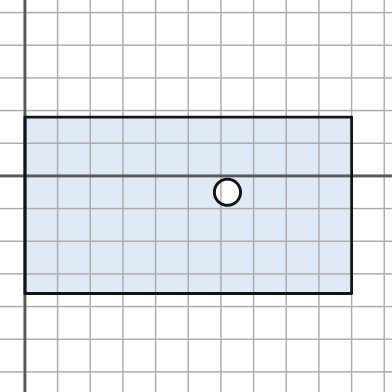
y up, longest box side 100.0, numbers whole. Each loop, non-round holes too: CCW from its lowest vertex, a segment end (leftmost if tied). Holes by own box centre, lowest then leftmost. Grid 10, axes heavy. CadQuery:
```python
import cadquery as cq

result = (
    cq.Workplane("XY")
    .moveTo(0.0, -36.0)
    .lineTo(100.0, -36.0)
    .lineTo(100.0, 18.0)
    .lineTo(0.0, 18.0)
    .close()
    .moveTo(62.0, -5.0)
    .circle(4.0)
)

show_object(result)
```